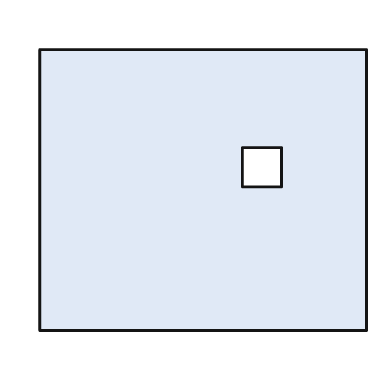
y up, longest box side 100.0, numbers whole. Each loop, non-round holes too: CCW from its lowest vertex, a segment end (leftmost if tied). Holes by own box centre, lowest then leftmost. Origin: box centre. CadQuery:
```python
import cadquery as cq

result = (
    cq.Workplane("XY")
    .moveTo(-50.0, -43.0)
    .lineTo(50.0, -43.0)
    .lineTo(50.0, 43.0)
    .lineTo(-50.0, 43.0)
    .close()
    .moveTo(12.0, 1.0)
    .lineTo(24.0, 1.0)
    .lineTo(24.0, 13.0)
    .lineTo(12.0, 13.0)
    .close()
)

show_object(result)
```